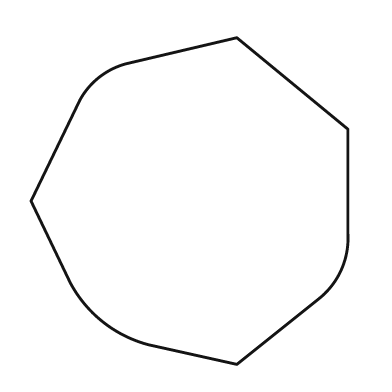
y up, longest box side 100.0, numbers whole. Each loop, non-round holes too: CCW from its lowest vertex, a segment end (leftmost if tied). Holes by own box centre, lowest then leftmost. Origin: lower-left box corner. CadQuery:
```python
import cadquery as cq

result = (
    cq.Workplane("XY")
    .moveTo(63.0, 0.0)
    .lineTo(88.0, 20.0)
    .threePointArc((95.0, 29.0), (97.0, 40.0))
    .lineTo(97.0, 72.0)
    .lineTo(63.0, 100.0)
    .lineTo(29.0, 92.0)
    .threePointArc((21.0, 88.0), (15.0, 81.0))
    .lineTo(0.0, 50.0)
    .lineTo(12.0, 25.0)
    .threePointArc((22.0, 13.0), (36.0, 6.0))
    .close()
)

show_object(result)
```